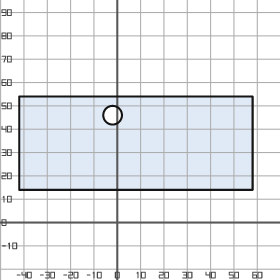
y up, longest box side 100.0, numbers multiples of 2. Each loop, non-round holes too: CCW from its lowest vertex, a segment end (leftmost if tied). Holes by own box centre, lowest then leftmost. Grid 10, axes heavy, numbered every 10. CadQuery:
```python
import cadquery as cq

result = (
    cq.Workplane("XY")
    .moveTo(-42.0, 14.0)
    .lineTo(58.0, 14.0)
    .lineTo(58.0, 54.0)
    .lineTo(-42.0, 54.0)
    .close()
    .moveTo(-2.0, 46.0)
    .circle(4.0)
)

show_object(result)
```